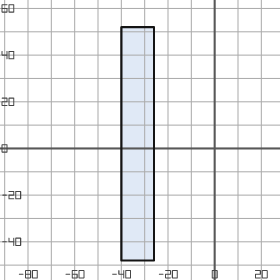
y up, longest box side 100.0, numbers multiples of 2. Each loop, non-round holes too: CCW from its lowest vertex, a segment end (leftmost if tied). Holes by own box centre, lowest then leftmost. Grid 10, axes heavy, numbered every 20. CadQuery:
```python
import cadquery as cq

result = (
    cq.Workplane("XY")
    .moveTo(-40.0, -48.0)
    .lineTo(-26.0, -48.0)
    .lineTo(-26.0, 52.0)
    .lineTo(-40.0, 52.0)
    .close()
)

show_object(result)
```